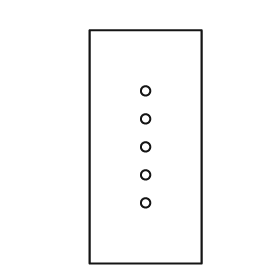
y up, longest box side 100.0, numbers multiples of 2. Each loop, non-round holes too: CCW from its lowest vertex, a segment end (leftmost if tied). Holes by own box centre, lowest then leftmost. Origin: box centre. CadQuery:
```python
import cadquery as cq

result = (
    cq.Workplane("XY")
    .moveTo(-24.0, -50.0)
    .lineTo(24.0, -50.0)
    .lineTo(24.0, 50.0)
    .lineTo(-24.0, 50.0)
    .close()
    .moveTo(0.0, -24.0)
    .circle(2.0)
    .moveTo(0.0, -12.0)
    .circle(2.0)
    .moveTo(0.0, 0.0)
    .circle(2.0)
    .moveTo(0.0, 12.0)
    .circle(2.0)
    .moveTo(0.0, 24.0)
    .circle(2.0)
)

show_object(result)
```